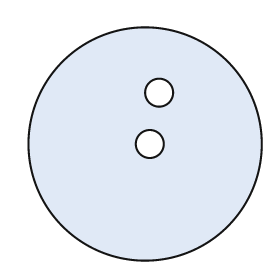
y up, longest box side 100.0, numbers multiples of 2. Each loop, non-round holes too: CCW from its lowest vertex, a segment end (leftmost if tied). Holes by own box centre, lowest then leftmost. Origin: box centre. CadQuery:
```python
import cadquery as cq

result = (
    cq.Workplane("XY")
    .moveTo(0.0, 0.0)
    .circle(50.0)
    .moveTo(2.0, 0.0)
    .circle(6.0)
    .moveTo(6.0, 22.0)
    .circle(6.0)
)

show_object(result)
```